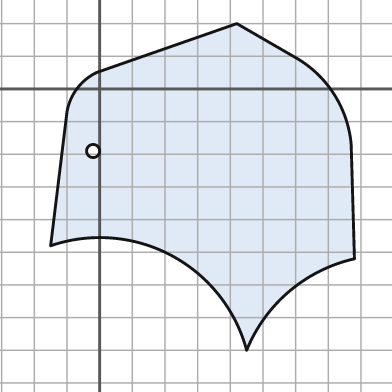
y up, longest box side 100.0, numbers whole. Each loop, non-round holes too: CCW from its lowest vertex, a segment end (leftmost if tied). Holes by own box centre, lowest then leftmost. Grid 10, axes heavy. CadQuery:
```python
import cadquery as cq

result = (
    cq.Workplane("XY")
    .moveTo(45.0, -80.0)
    .threePointArc((58.0, -62.0), (78.0, -52.0))
    .lineTo(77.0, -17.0)
    .threePointArc((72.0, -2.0), (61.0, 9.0))
    .lineTo(42.0, 20.0)
    .lineTo(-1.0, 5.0)
    .threePointArc((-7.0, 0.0), (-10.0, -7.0))
    .lineTo(-15.0, -48.0)
    .threePointArc((22.0, -51.0), (45.0, -80.0))
    .close()
    .moveTo(-2.0, -19.0)
    .circle(2.0)
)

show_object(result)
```